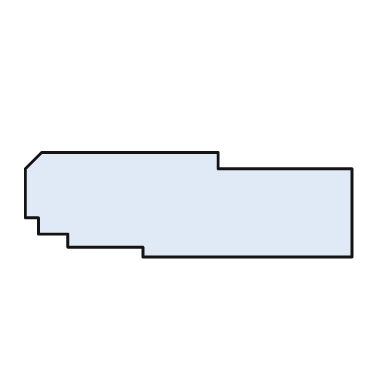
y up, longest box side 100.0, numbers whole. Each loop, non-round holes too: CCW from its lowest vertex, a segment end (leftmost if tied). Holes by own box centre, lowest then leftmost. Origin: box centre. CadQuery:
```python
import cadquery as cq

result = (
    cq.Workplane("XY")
    .moveTo(-14.0, -16.0)
    .lineTo(50.0, -16.0)
    .lineTo(50.0, 11.0)
    .lineTo(9.0, 11.0)
    .lineTo(9.0, 16.0)
    .lineTo(-45.0, 16.0)
    .lineTo(-50.0, 11.0)
    .lineTo(-50.0, -4.0)
    .lineTo(-46.0, -4.0)
    .lineTo(-46.0, -9.0)
    .lineTo(-37.0, -9.0)
    .lineTo(-37.0, -13.0)
    .lineTo(-14.0, -13.0)
    .close()
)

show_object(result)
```